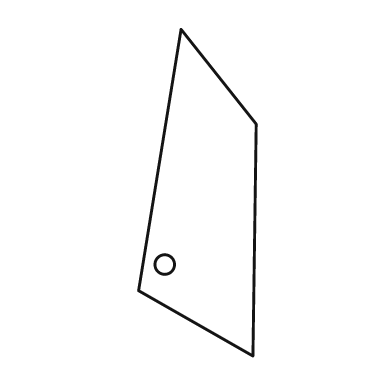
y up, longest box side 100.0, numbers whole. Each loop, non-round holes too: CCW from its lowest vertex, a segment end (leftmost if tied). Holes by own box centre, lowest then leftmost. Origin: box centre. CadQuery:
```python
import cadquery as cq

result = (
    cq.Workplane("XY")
    .moveTo(17.0, -50.0)
    .lineTo(18.0, 21.0)
    .lineTo(-5.0, 50.0)
    .lineTo(-18.0, -30.0)
    .close()
    .moveTo(-10.0, -22.0)
    .circle(3.0)
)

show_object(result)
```